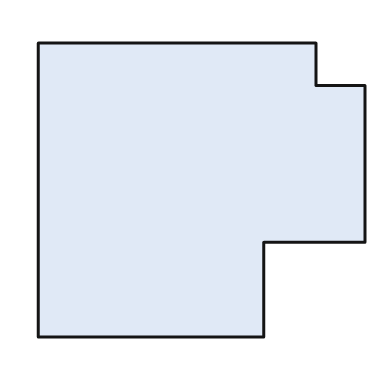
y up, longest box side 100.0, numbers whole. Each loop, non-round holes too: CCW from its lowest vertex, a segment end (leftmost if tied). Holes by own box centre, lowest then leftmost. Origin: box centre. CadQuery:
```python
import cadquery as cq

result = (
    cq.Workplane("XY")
    .moveTo(-50.0, -45.0)
    .lineTo(19.0, -45.0)
    .lineTo(19.0, -16.0)
    .lineTo(50.0, -16.0)
    .lineTo(50.0, 32.0)
    .lineTo(35.0, 32.0)
    .lineTo(35.0, 45.0)
    .lineTo(-50.0, 45.0)
    .close()
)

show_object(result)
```